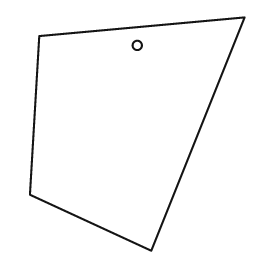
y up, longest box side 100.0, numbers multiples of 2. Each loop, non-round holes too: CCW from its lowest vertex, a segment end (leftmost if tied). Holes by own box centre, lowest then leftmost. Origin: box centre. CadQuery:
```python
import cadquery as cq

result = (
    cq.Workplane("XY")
    .moveTo(6.0, -50.0)
    .lineTo(46.0, 50.0)
    .lineTo(-42.0, 42.0)
    .lineTo(-46.0, -26.0)
    .close()
    .moveTo(0.0, 38.0)
    .circle(2.0)
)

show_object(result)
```